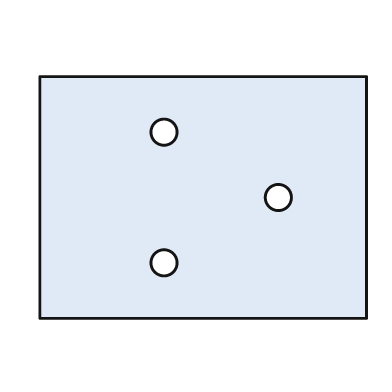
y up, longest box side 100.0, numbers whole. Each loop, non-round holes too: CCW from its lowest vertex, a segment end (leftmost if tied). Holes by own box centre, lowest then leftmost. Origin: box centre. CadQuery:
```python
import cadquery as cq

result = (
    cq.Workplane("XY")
    .moveTo(-50.0, -37.0)
    .lineTo(50.0, -37.0)
    .lineTo(50.0, 37.0)
    .lineTo(-50.0, 37.0)
    .close()
    .moveTo(-12.0, -20.0)
    .circle(4.0)
    .moveTo(23.0, 0.0)
    .circle(4.0)
    .moveTo(-12.0, 20.0)
    .circle(4.0)
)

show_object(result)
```